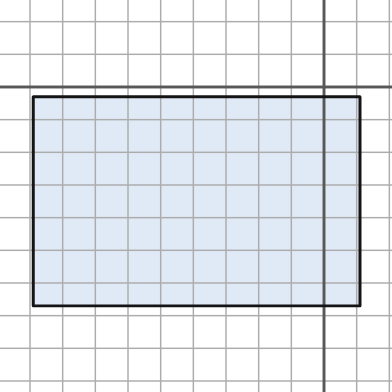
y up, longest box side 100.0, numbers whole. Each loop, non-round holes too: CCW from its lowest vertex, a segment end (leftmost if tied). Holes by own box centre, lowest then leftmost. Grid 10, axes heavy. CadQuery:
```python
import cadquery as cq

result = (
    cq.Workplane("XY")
    .moveTo(-89.0, -67.0)
    .lineTo(11.0, -67.0)
    .lineTo(11.0, -3.0)
    .lineTo(-89.0, -3.0)
    .close()
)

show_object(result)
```